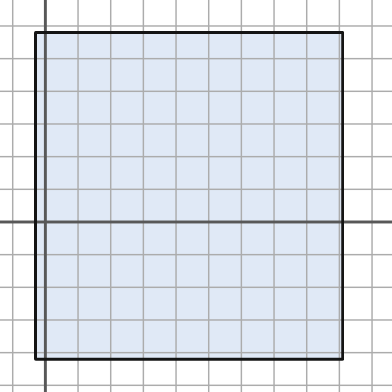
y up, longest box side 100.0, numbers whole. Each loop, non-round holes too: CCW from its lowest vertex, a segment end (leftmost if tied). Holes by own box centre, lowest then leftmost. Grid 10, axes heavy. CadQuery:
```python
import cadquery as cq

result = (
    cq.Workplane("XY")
    .moveTo(-3.0, -42.0)
    .lineTo(91.0, -42.0)
    .lineTo(91.0, 58.0)
    .lineTo(-3.0, 58.0)
    .close()
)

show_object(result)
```